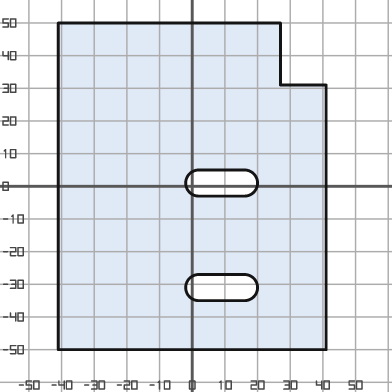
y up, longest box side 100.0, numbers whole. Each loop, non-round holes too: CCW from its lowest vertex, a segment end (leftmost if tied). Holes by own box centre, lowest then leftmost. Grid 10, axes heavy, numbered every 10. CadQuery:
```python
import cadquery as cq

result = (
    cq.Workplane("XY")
    .moveTo(-41.0, -50.0)
    .lineTo(41.0, -50.0)
    .lineTo(41.0, 31.0)
    .lineTo(27.0, 31.0)
    .lineTo(27.0, 50.0)
    .lineTo(-41.0, 50.0)
    .close()
    .moveTo(2.0, -35.0)
    .lineTo(16.0, -35.0)
    .threePointArc((20.0, -31.0), (16.0, -27.0))
    .lineTo(2.0, -27.0)
    .threePointArc((-2.0, -31.0), (2.0, -35.0))
    .close()
    .moveTo(2.0, -3.0)
    .lineTo(16.0, -3.0)
    .threePointArc((20.0, 1.0), (16.0, 5.0))
    .lineTo(2.0, 5.0)
    .threePointArc((-2.0, 1.0), (2.0, -3.0))
    .close()
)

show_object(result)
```